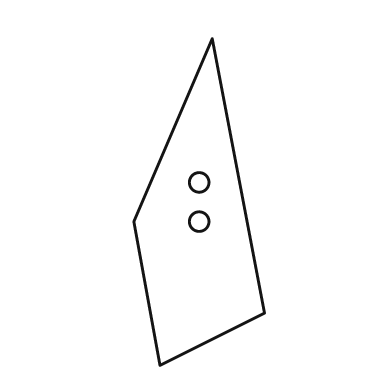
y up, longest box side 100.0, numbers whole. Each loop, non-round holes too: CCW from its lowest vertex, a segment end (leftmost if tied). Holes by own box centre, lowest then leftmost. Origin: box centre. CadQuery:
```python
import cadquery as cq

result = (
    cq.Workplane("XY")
    .moveTo(-12.0, -50.0)
    .lineTo(20.0, -34.0)
    .lineTo(4.0, 50.0)
    .lineTo(-20.0, -6.0)
    .close()
    .moveTo(0.0, -6.0)
    .circle(3.0)
    .moveTo(0.0, 6.0)
    .circle(3.0)
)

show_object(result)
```